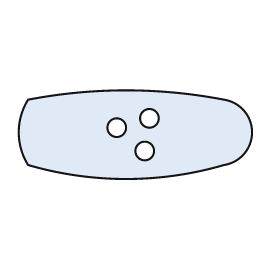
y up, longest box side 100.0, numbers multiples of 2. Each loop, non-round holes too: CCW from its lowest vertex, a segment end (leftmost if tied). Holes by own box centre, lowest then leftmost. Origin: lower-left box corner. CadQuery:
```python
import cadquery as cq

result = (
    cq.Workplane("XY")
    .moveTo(4.0, 6.0)
    .threePointArc((46.0, 0.0), (88.0, 6.0))
    .threePointArc((100.0, 20.0), (88.0, 34.0))
    .threePointArc((46.0, 38.0), (4.0, 34.0))
    .threePointArc((0.0, 20.0), (4.0, 6.0))
    .close()
    .moveTo(54.0, 12.0)
    .circle(4.0)
    .moveTo(42.0, 22.0)
    .circle(4.0)
    .moveTo(56.0, 26.0)
    .circle(4.0)
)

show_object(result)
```